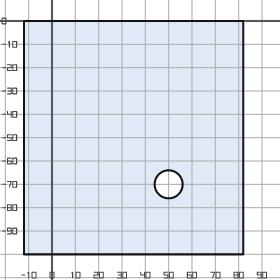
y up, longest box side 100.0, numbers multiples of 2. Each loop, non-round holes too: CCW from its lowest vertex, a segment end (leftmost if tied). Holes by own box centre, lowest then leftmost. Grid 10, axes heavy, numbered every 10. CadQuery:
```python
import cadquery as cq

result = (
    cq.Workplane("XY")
    .moveTo(-12.0, -100.0)
    .lineTo(82.0, -100.0)
    .lineTo(82.0, 0.0)
    .lineTo(-12.0, 0.0)
    .close()
    .moveTo(50.0, -70.0)
    .circle(6.0)
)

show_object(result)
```